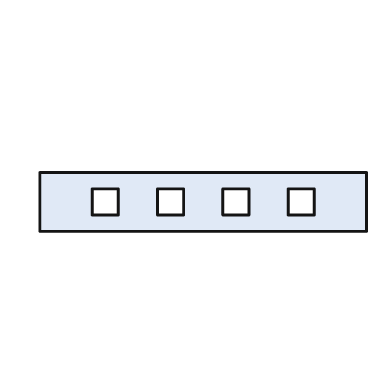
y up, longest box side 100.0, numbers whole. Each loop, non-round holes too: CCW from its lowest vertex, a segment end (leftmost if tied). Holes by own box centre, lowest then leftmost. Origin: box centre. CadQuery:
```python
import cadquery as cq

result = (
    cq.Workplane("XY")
    .moveTo(-50.0, -9.0)
    .lineTo(50.0, -9.0)
    .lineTo(50.0, 9.0)
    .lineTo(-50.0, 9.0)
    .close()
    .moveTo(-34.0, -4.0)
    .lineTo(-26.0, -4.0)
    .lineTo(-26.0, 4.0)
    .lineTo(-34.0, 4.0)
    .close()
    .moveTo(-14.0, -4.0)
    .lineTo(-6.0, -4.0)
    .lineTo(-6.0, 4.0)
    .lineTo(-14.0, 4.0)
    .close()
    .moveTo(6.0, -4.0)
    .lineTo(14.0, -4.0)
    .lineTo(14.0, 4.0)
    .lineTo(6.0, 4.0)
    .close()
    .moveTo(26.0, -4.0)
    .lineTo(34.0, -4.0)
    .lineTo(34.0, 4.0)
    .lineTo(26.0, 4.0)
    .close()
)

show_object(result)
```